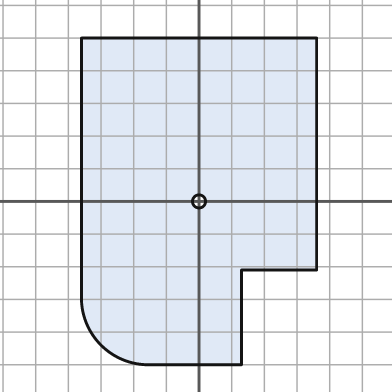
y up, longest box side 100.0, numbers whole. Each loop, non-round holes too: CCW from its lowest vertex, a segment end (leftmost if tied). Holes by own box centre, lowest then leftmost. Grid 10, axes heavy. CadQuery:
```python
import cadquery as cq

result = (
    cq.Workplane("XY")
    .moveTo(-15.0, -50.0)
    .lineTo(13.0, -50.0)
    .lineTo(13.0, -21.0)
    .lineTo(36.0, -21.0)
    .lineTo(36.0, 50.0)
    .lineTo(-36.0, 50.0)
    .lineTo(-36.0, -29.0)
    .threePointArc((-30.0, -44.0), (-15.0, -50.0))
    .close()
    .moveTo(0.0, 0.0)
    .circle(2.0)
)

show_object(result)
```